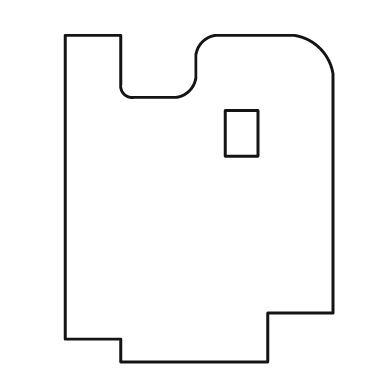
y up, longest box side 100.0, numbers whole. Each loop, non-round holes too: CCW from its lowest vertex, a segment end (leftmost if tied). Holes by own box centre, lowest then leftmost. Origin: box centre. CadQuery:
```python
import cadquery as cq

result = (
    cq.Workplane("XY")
    .moveTo(-24.0, -50.0)
    .lineTo(21.0, -50.0)
    .lineTo(21.0, -35.0)
    .lineTo(41.0, -35.0)
    .lineTo(41.0, 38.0)
    .threePointArc((37.0, 46.0), (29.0, 50.0))
    .lineTo(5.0, 50.0)
    .threePointArc((1.0, 48.0), (-1.0, 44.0))
    .lineTo(-1.0, 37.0)
    .threePointArc((-3.0, 33.0), (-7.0, 31.0))
    .lineTo(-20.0, 31.0)
    .threePointArc((-23.0, 32.0), (-24.0, 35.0))
    .lineTo(-24.0, 50.0)
    .lineTo(-41.0, 50.0)
    .lineTo(-41.0, -43.0)
    .lineTo(-24.0, -43.0)
    .close()
    .moveTo(8.0, 13.0)
    .lineTo(18.0, 13.0)
    .lineTo(18.0, 27.0)
    .lineTo(8.0, 27.0)
    .close()
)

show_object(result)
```